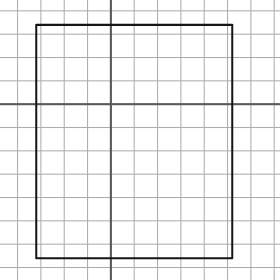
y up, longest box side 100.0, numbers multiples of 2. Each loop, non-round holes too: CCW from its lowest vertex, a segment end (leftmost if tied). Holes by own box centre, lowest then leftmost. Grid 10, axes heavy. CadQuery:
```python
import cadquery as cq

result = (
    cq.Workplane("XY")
    .moveTo(-32.0, -66.0)
    .lineTo(52.0, -66.0)
    .lineTo(52.0, 34.0)
    .lineTo(-32.0, 34.0)
    .close()
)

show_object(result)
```